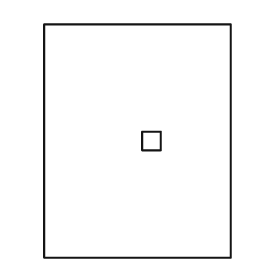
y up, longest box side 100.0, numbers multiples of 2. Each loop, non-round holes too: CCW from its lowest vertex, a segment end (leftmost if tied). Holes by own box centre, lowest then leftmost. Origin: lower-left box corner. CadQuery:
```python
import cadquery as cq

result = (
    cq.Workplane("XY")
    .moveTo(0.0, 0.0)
    .lineTo(80.0, 0.0)
    .lineTo(80.0, 100.0)
    .lineTo(0.0, 100.0)
    .close()
    .moveTo(42.0, 46.0)
    .lineTo(50.0, 46.0)
    .lineTo(50.0, 54.0)
    .lineTo(42.0, 54.0)
    .close()
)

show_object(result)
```